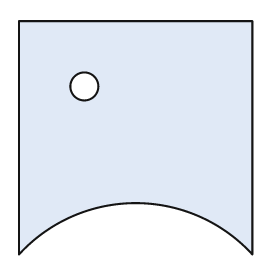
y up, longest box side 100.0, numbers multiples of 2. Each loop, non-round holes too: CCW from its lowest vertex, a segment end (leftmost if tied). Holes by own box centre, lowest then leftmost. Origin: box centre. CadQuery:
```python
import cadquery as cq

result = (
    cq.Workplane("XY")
    .moveTo(-50.0, -50.0)
    .threePointArc((0.0, -28.0), (50.0, -50.0))
    .lineTo(50.0, 50.0)
    .lineTo(-50.0, 50.0)
    .close()
    .moveTo(-22.0, 22.0)
    .circle(6.0)
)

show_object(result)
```